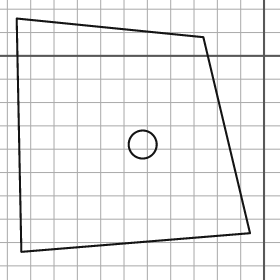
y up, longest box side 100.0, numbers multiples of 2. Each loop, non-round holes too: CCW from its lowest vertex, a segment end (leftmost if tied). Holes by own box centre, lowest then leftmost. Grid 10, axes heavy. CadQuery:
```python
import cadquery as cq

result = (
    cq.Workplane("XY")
    .moveTo(-104.0, -84.0)
    .lineTo(-6.0, -76.0)
    .lineTo(-26.0, 8.0)
    .lineTo(-106.0, 16.0)
    .close()
    .moveTo(-52.0, -38.0)
    .circle(6.0)
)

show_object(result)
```